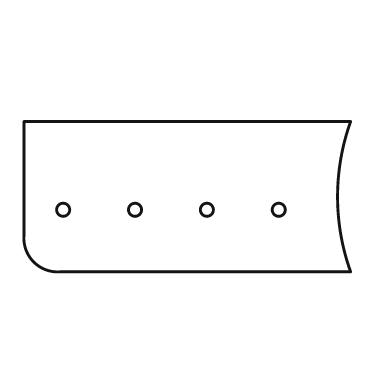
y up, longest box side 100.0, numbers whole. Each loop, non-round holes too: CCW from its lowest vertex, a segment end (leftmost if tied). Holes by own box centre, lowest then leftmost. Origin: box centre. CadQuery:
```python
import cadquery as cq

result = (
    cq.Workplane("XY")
    .moveTo(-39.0, -23.0)
    .lineTo(50.0, -23.0)
    .threePointArc((46.0, 0.0), (50.0, 23.0))
    .lineTo(-50.0, 23.0)
    .lineTo(-50.0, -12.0)
    .threePointArc((-47.0, -20.0), (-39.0, -23.0))
    .close()
    .moveTo(-38.0, -4.0)
    .circle(2.0)
    .moveTo(-16.0, -4.0)
    .circle(2.0)
    .moveTo(6.0, -4.0)
    .circle(2.0)
    .moveTo(28.0, -4.0)
    .circle(2.0)
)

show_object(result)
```